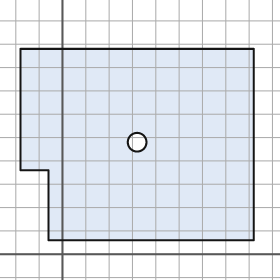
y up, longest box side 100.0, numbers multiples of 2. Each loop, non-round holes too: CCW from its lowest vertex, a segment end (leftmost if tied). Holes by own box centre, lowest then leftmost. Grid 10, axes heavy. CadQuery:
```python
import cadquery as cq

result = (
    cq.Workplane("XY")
    .moveTo(-6.0, 6.0)
    .lineTo(82.0, 6.0)
    .lineTo(82.0, 88.0)
    .lineTo(-18.0, 88.0)
    .lineTo(-18.0, 36.0)
    .lineTo(-6.0, 36.0)
    .close()
    .moveTo(32.0, 48.0)
    .circle(4.0)
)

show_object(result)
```